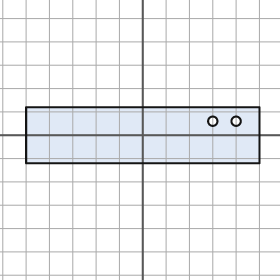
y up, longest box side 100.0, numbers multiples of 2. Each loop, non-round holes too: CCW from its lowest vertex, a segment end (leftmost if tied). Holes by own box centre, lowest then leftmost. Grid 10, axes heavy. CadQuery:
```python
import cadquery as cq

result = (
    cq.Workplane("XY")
    .moveTo(-50.0, -12.0)
    .lineTo(50.0, -12.0)
    .lineTo(50.0, 12.0)
    .lineTo(-50.0, 12.0)
    .close()
    .moveTo(30.0, 6.0)
    .circle(2.0)
    .moveTo(40.0, 6.0)
    .circle(2.0)
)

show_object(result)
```